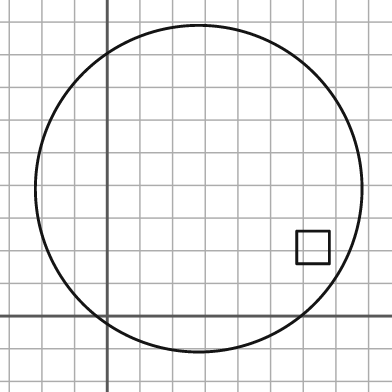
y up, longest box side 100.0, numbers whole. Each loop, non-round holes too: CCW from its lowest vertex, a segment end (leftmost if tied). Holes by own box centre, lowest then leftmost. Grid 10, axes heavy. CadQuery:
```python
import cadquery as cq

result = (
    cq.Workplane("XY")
    .moveTo(28.0, 39.0)
    .circle(50.0)
    .moveTo(58.0, 16.0)
    .lineTo(68.0, 16.0)
    .lineTo(68.0, 26.0)
    .lineTo(58.0, 26.0)
    .close()
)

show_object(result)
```